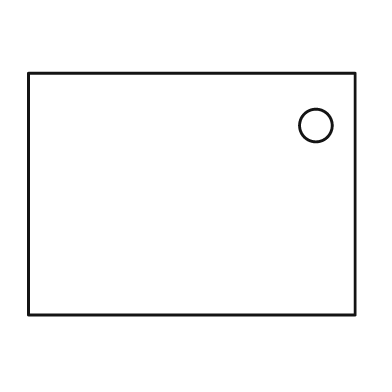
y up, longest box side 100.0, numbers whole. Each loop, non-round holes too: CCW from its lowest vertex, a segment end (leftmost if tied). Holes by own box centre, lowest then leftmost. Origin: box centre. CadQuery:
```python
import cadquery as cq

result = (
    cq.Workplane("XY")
    .moveTo(-50.0, -37.0)
    .lineTo(50.0, -37.0)
    .lineTo(50.0, 37.0)
    .lineTo(-50.0, 37.0)
    .close()
    .moveTo(38.0, 21.0)
    .circle(5.0)
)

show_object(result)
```